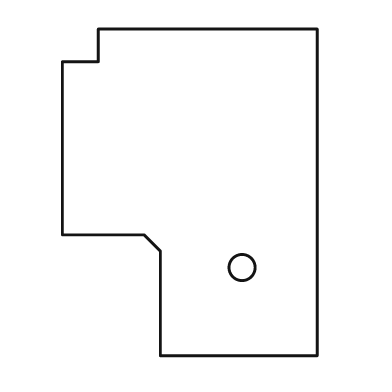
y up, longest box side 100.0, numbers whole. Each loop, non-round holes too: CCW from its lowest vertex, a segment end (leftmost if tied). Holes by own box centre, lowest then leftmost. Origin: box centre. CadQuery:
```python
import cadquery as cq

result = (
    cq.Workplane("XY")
    .moveTo(-9.0, -50.0)
    .lineTo(39.0, -50.0)
    .lineTo(39.0, 50.0)
    .lineTo(-28.0, 50.0)
    .lineTo(-28.0, 40.0)
    .lineTo(-39.0, 40.0)
    .lineTo(-39.0, -13.0)
    .lineTo(-14.0, -13.0)
    .lineTo(-9.0, -18.0)
    .close()
    .moveTo(16.0, -23.0)
    .circle(4.0)
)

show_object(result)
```